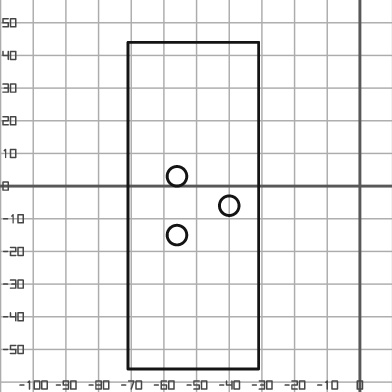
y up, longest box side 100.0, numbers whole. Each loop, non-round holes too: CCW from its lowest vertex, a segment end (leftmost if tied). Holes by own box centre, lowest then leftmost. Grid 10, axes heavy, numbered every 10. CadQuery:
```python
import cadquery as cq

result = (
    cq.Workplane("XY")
    .moveTo(-71.0, -56.0)
    .lineTo(-31.0, -56.0)
    .lineTo(-31.0, 44.0)
    .lineTo(-71.0, 44.0)
    .close()
    .moveTo(-56.0, -15.0)
    .circle(3.0)
    .moveTo(-40.0, -6.0)
    .circle(3.0)
    .moveTo(-56.0, 3.0)
    .circle(3.0)
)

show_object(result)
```